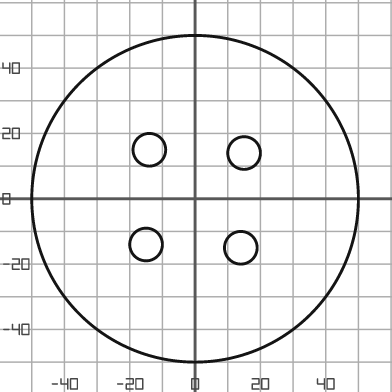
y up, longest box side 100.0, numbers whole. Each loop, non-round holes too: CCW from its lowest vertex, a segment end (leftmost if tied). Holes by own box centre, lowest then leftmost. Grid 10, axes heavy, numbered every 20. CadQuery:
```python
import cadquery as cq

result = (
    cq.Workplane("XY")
    .moveTo(0.0, 0.0)
    .circle(50.0)
    .moveTo(14.0, -15.0)
    .circle(5.0)
    .moveTo(-15.0, -14.0)
    .circle(5.0)
    .moveTo(15.0, 14.0)
    .circle(5.0)
    .moveTo(-14.0, 15.0)
    .circle(5.0)
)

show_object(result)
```